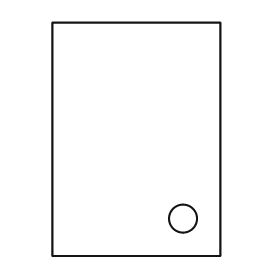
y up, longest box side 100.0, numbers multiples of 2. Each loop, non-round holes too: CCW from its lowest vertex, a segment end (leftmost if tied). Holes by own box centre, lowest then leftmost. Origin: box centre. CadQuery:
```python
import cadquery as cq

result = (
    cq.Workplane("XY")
    .moveTo(-36.0, -50.0)
    .lineTo(36.0, -50.0)
    .lineTo(36.0, 50.0)
    .lineTo(-36.0, 50.0)
    .close()
    .moveTo(20.0, -34.0)
    .circle(6.0)
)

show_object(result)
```